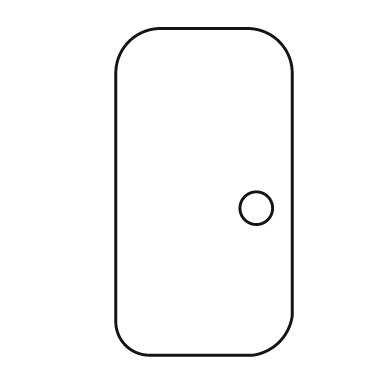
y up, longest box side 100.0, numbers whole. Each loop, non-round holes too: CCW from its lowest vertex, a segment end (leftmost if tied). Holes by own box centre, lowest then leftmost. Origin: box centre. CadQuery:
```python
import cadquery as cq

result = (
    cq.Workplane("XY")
    .moveTo(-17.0, -50.0)
    .lineTo(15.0, -50.0)
    .threePointArc((23.0, -46.0), (27.0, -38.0))
    .lineTo(27.0, 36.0)
    .threePointArc((23.0, 46.0), (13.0, 50.0))
    .lineTo(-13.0, 50.0)
    .threePointArc((-23.0, 46.0), (-27.0, 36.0))
    .lineTo(-27.0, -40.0)
    .threePointArc((-24.0, -47.0), (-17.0, -50.0))
    .close()
    .moveTo(16.0, -5.0)
    .circle(5.0)
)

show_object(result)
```